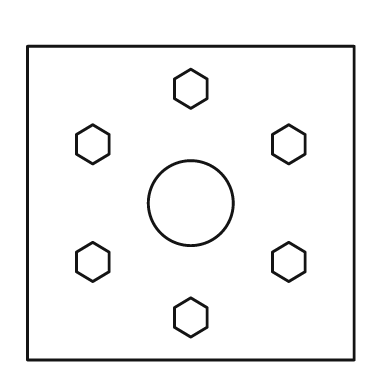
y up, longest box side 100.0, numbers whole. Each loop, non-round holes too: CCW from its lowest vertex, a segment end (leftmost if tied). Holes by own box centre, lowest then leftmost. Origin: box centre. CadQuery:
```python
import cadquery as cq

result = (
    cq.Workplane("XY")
    .moveTo(-50.0, -48.0)
    .lineTo(50.0, -48.0)
    .lineTo(50.0, 48.0)
    .lineTo(-50.0, 48.0)
    .close()
    .moveTo(0.0, -41.0)
    .lineTo(5.0, -38.0)
    .lineTo(5.0, -32.0)
    .lineTo(0.0, -29.0)
    .lineTo(-5.0, -32.0)
    .lineTo(-5.0, -38.0)
    .close()
    .moveTo(-30.0, -24.0)
    .lineTo(-25.0, -21.0)
    .lineTo(-25.0, -15.0)
    .lineTo(-30.0, -12.0)
    .lineTo(-35.0, -15.0)
    .lineTo(-35.0, -21.0)
    .close()
    .moveTo(30.0, -24.0)
    .lineTo(35.0, -21.0)
    .lineTo(35.0, -15.0)
    .lineTo(30.0, -12.0)
    .lineTo(25.0, -15.0)
    .lineTo(25.0, -21.0)
    .close()
    .moveTo(0.0, 0.0)
    .circle(13.0)
    .moveTo(-30.0, 12.0)
    .lineTo(-25.0, 15.0)
    .lineTo(-25.0, 21.0)
    .lineTo(-30.0, 24.0)
    .lineTo(-35.0, 21.0)
    .lineTo(-35.0, 15.0)
    .close()
    .moveTo(30.0, 12.0)
    .lineTo(35.0, 15.0)
    .lineTo(35.0, 21.0)
    .lineTo(30.0, 24.0)
    .lineTo(25.0, 21.0)
    .lineTo(25.0, 15.0)
    .close()
    .moveTo(0.0, 29.0)
    .lineTo(5.0, 32.0)
    .lineTo(5.0, 38.0)
    .lineTo(0.0, 41.0)
    .lineTo(-5.0, 38.0)
    .lineTo(-5.0, 32.0)
    .close()
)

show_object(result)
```